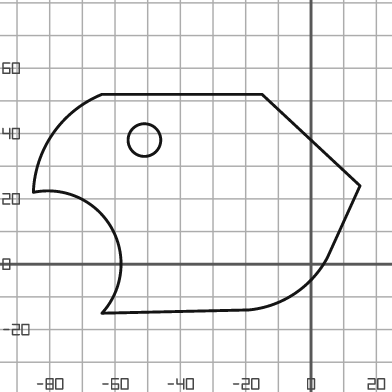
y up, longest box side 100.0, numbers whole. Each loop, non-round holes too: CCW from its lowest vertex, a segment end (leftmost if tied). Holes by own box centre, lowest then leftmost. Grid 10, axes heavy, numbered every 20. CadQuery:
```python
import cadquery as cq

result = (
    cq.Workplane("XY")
    .moveTo(-64.0, -15.0)
    .lineTo(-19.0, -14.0)
    .threePointArc((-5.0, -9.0), (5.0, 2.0))
    .lineTo(15.0, 24.0)
    .lineTo(-15.0, 52.0)
    .lineTo(-64.0, 52.0)
    .threePointArc((-79.0, 40.0), (-85.0, 22.0))
    .threePointArc((-61.0, 11.0), (-64.0, -15.0))
    .close()
    .moveTo(-51.0, 38.0)
    .circle(5.0)
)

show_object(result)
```